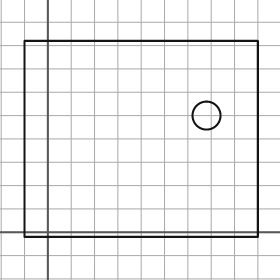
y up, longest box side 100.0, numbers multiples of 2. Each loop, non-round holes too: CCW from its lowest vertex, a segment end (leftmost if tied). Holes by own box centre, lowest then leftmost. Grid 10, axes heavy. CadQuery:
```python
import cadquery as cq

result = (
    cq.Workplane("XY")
    .moveTo(-10.0, -2.0)
    .lineTo(90.0, -2.0)
    .lineTo(90.0, 82.0)
    .lineTo(-10.0, 82.0)
    .close()
    .moveTo(68.0, 50.0)
    .circle(6.0)
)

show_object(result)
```